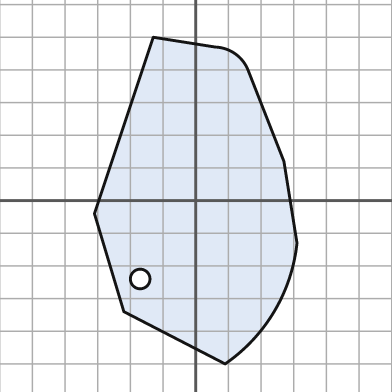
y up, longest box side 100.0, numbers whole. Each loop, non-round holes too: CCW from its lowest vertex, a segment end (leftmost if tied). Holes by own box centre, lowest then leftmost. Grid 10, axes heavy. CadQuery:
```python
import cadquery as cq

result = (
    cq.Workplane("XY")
    .moveTo(9.0, -50.0)
    .threePointArc((24.0, -34.0), (31.0, -13.0))
    .lineTo(27.0, 12.0)
    .lineTo(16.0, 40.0)
    .threePointArc((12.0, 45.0), (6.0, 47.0))
    .lineTo(-13.0, 50.0)
    .lineTo(-31.0, -4.0)
    .lineTo(-22.0, -34.0)
    .close()
    .moveTo(-17.0, -24.0)
    .circle(3.0)
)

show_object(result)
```